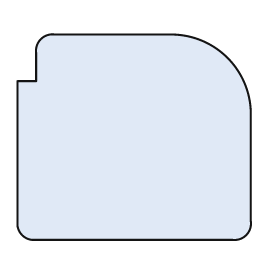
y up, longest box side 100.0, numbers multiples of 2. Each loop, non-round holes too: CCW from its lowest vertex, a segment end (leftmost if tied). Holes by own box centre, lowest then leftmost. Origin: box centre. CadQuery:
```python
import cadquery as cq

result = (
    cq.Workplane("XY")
    .moveTo(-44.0, -44.0)
    .lineTo(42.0, -44.0)
    .threePointArc((48.0, -42.0), (50.0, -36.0))
    .lineTo(50.0, 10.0)
    .threePointArc((40.0, 34.0), (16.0, 44.0))
    .lineTo(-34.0, 44.0)
    .threePointArc((-40.0, 42.0), (-42.0, 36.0))
    .lineTo(-42.0, 24.0)
    .lineTo(-50.0, 24.0)
    .lineTo(-50.0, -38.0)
    .threePointArc((-48.0, -42.0), (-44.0, -44.0))
    .close()
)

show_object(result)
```